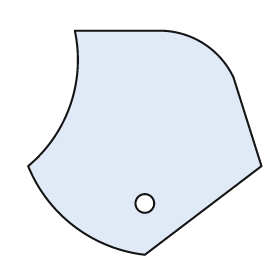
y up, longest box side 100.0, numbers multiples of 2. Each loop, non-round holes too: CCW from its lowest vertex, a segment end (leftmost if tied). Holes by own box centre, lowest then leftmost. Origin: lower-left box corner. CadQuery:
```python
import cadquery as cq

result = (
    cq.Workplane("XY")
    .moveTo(50.0, 0.0)
    .lineTo(100.0, 38.0)
    .lineTo(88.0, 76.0)
    .threePointArc((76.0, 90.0), (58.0, 96.0))
    .lineTo(20.0, 96.0)
    .threePointArc((18.0, 64.0), (0.0, 38.0))
    .threePointArc((20.0, 12.0), (50.0, 0.0))
    .close()
    .moveTo(50.0, 22.0)
    .circle(4.0)
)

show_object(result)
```